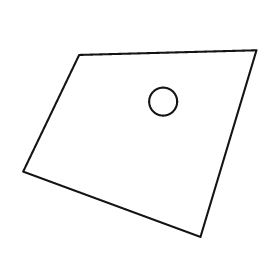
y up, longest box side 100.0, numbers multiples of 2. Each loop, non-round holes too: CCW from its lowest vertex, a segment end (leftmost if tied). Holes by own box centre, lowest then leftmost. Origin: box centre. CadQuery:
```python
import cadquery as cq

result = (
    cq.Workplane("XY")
    .moveTo(26.0, -40.0)
    .lineTo(50.0, 40.0)
    .lineTo(-26.0, 38.0)
    .lineTo(-50.0, -12.0)
    .close()
    .moveTo(10.0, 18.0)
    .circle(6.0)
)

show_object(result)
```